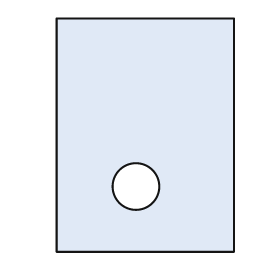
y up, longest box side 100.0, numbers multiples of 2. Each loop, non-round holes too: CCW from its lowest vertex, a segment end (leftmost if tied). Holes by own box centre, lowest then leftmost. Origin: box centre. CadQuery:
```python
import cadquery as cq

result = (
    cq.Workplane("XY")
    .moveTo(-38.0, -50.0)
    .lineTo(38.0, -50.0)
    .lineTo(38.0, 50.0)
    .lineTo(-38.0, 50.0)
    .close()
    .moveTo(-4.0, -22.0)
    .circle(10.0)
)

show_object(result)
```